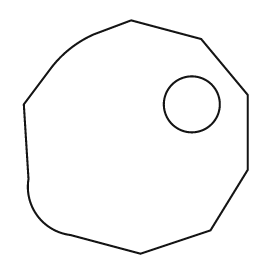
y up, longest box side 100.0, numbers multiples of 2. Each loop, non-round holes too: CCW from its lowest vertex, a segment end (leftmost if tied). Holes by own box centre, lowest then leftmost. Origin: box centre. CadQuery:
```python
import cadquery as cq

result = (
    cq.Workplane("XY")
    .moveTo(2.0, -50.0)
    .lineTo(32.0, -40.0)
    .lineTo(48.0, -14.0)
    .lineTo(48.0, 18.0)
    .lineTo(28.0, 42.0)
    .lineTo(-2.0, 50.0)
    .lineTo(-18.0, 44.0)
    .threePointArc((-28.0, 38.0), (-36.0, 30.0))
    .lineTo(-48.0, 14.0)
    .lineTo(-46.0, -18.0)
    .threePointArc((-42.0, -34.0), (-28.0, -42.0))
    .close()
    .moveTo(24.0, 14.0)
    .circle(12.0)
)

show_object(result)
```